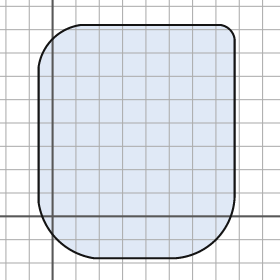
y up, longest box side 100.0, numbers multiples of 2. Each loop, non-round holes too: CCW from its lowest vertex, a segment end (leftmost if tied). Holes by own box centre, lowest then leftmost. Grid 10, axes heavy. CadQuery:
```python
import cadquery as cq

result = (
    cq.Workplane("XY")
    .moveTo(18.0, -18.0)
    .lineTo(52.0, -18.0)
    .threePointArc((70.0, -10.0), (78.0, 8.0))
    .lineTo(78.0, 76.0)
    .threePointArc((76.0, 80.0), (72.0, 82.0))
    .lineTo(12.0, 82.0)
    .threePointArc((0.0, 76.0), (-6.0, 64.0))
    .lineTo(-6.0, 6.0)
    .threePointArc((2.0, -10.0), (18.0, -18.0))
    .close()
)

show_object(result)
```